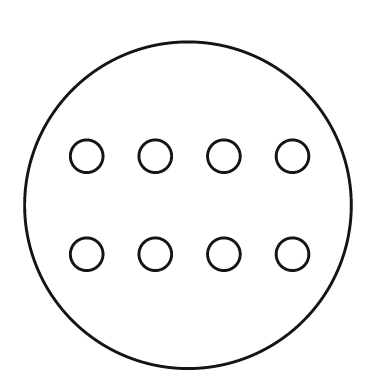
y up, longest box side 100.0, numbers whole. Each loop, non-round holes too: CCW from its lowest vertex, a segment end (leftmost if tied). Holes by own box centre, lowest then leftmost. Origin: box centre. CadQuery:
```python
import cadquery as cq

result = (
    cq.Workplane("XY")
    .moveTo(0.0, 0.0)
    .circle(50.0)
    .moveTo(-31.0, -15.0)
    .circle(5.0)
    .moveTo(-10.0, -15.0)
    .circle(5.0)
    .moveTo(11.0, -15.0)
    .circle(5.0)
    .moveTo(32.0, -15.0)
    .circle(5.0)
    .moveTo(-31.0, 15.0)
    .circle(5.0)
    .moveTo(-10.0, 15.0)
    .circle(5.0)
    .moveTo(11.0, 15.0)
    .circle(5.0)
    .moveTo(32.0, 15.0)
    .circle(5.0)
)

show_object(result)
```